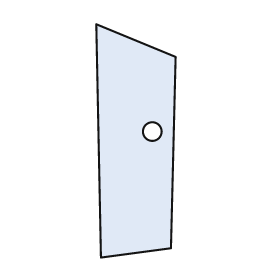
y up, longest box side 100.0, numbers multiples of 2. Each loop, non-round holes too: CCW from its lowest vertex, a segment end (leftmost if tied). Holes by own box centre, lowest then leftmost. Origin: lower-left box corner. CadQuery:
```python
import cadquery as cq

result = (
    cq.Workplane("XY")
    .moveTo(2.0, 0.0)
    .lineTo(32.0, 4.0)
    .lineTo(34.0, 86.0)
    .lineTo(0.0, 100.0)
    .close()
    .moveTo(24.0, 54.0)
    .circle(4.0)
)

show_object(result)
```